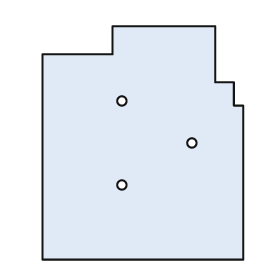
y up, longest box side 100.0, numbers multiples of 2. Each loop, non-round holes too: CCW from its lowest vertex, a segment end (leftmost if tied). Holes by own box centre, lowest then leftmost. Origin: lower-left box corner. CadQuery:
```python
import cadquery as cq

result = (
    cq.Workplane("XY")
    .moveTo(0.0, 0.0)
    .lineTo(86.0, 0.0)
    .lineTo(86.0, 66.0)
    .lineTo(82.0, 66.0)
    .lineTo(82.0, 76.0)
    .lineTo(74.0, 76.0)
    .lineTo(74.0, 100.0)
    .lineTo(30.0, 100.0)
    .lineTo(30.0, 88.0)
    .lineTo(0.0, 88.0)
    .close()
    .moveTo(34.0, 32.0)
    .circle(2.0)
    .moveTo(64.0, 50.0)
    .circle(2.0)
    .moveTo(34.0, 68.0)
    .circle(2.0)
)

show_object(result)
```